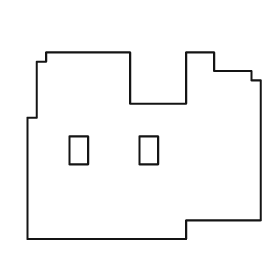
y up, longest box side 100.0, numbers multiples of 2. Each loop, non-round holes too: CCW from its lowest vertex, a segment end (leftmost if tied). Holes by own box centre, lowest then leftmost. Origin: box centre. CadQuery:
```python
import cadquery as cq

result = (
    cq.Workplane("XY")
    .moveTo(-50.0, -40.0)
    .lineTo(18.0, -40.0)
    .lineTo(18.0, -32.0)
    .lineTo(50.0, -32.0)
    .lineTo(50.0, 28.0)
    .lineTo(46.0, 28.0)
    .lineTo(46.0, 32.0)
    .lineTo(30.0, 32.0)
    .lineTo(30.0, 40.0)
    .lineTo(18.0, 40.0)
    .lineTo(18.0, 18.0)
    .lineTo(-6.0, 18.0)
    .lineTo(-6.0, 40.0)
    .lineTo(-42.0, 40.0)
    .lineTo(-42.0, 36.0)
    .lineTo(-46.0, 36.0)
    .lineTo(-46.0, 12.0)
    .lineTo(-50.0, 12.0)
    .close()
    .moveTo(-32.0, -8.0)
    .lineTo(-24.0, -8.0)
    .lineTo(-24.0, 4.0)
    .lineTo(-32.0, 4.0)
    .close()
    .moveTo(-2.0, -8.0)
    .lineTo(6.0, -8.0)
    .lineTo(6.0, 4.0)
    .lineTo(-2.0, 4.0)
    .close()
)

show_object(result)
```